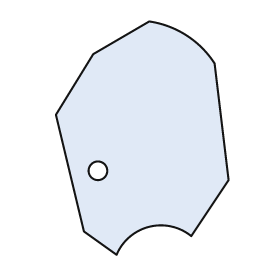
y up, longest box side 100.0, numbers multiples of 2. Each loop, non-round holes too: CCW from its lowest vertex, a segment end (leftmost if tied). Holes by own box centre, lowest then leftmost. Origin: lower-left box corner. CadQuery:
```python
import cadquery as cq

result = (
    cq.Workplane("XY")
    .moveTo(26.0, 0.0)
    .threePointArc((40.0, 12.0), (58.0, 8.0))
    .lineTo(74.0, 32.0)
    .lineTo(68.0, 82.0)
    .threePointArc((56.0, 94.0), (40.0, 100.0))
    .lineTo(16.0, 86.0)
    .lineTo(0.0, 60.0)
    .lineTo(12.0, 10.0)
    .close()
    .moveTo(18.0, 36.0)
    .circle(4.0)
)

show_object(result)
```